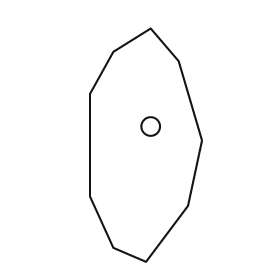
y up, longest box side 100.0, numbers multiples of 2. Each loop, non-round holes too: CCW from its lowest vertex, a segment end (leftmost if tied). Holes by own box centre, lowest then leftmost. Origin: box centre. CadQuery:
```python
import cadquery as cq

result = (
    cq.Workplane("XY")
    .moveTo(0.0, -50.0)
    .lineTo(18.0, -26.0)
    .lineTo(24.0, 2.0)
    .lineTo(14.0, 36.0)
    .lineTo(2.0, 50.0)
    .lineTo(-14.0, 40.0)
    .lineTo(-24.0, 22.0)
    .lineTo(-24.0, -22.0)
    .lineTo(-14.0, -44.0)
    .close()
    .moveTo(2.0, 8.0)
    .circle(4.0)
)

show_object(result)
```